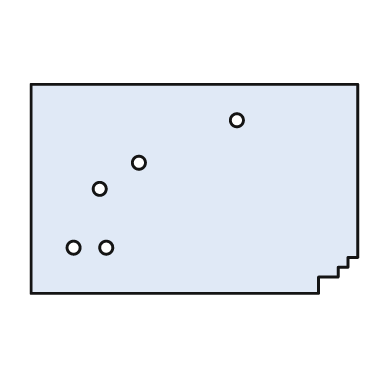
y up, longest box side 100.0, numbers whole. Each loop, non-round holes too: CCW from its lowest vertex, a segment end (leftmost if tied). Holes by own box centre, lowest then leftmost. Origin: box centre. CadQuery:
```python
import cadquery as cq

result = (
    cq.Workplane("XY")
    .moveTo(-50.0, -32.0)
    .lineTo(38.0, -32.0)
    .lineTo(38.0, -27.0)
    .lineTo(44.0, -27.0)
    .lineTo(44.0, -24.0)
    .lineTo(47.0, -24.0)
    .lineTo(47.0, -21.0)
    .lineTo(50.0, -21.0)
    .lineTo(50.0, 32.0)
    .lineTo(-50.0, 32.0)
    .close()
    .moveTo(-37.0, -18.0)
    .circle(2.0)
    .moveTo(-27.0, -18.0)
    .circle(2.0)
    .moveTo(-29.0, 0.0)
    .circle(2.0)
    .moveTo(-17.0, 8.0)
    .circle(2.0)
    .moveTo(13.0, 21.0)
    .circle(2.0)
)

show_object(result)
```